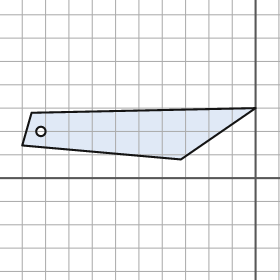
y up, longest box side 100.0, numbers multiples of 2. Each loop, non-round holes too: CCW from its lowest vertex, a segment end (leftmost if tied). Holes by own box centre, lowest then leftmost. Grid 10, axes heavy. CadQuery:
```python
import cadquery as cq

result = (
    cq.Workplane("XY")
    .moveTo(-32.0, 8.0)
    .lineTo(0.0, 30.0)
    .lineTo(-96.0, 28.0)
    .lineTo(-100.0, 14.0)
    .close()
    .moveTo(-92.0, 20.0)
    .circle(2.0)
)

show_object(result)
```